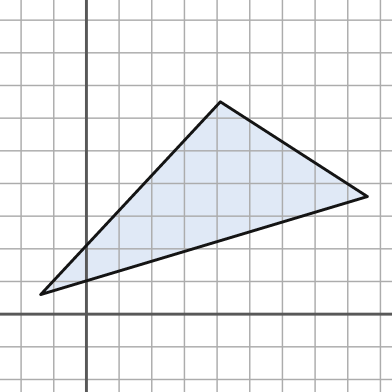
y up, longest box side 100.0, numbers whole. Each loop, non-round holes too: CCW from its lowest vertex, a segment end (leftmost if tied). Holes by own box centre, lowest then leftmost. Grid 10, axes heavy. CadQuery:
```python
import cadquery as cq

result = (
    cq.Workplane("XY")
    .moveTo(-14.0, 6.0)
    .lineTo(86.0, 36.0)
    .lineTo(41.0, 65.0)
    .close()
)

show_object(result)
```